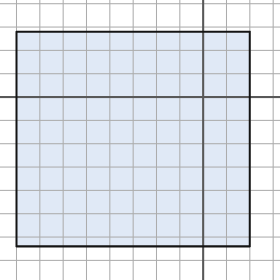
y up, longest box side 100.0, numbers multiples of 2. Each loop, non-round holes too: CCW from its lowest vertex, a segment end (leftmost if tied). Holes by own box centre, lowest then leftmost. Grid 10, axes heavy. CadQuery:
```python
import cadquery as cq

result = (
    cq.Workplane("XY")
    .moveTo(-80.0, -64.0)
    .lineTo(20.0, -64.0)
    .lineTo(20.0, 28.0)
    .lineTo(-80.0, 28.0)
    .close()
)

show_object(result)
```